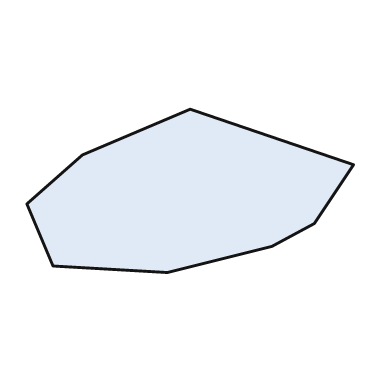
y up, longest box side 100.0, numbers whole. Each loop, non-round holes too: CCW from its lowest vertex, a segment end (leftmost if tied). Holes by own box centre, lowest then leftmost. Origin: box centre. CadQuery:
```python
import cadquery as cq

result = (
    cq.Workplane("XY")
    .moveTo(-7.0, -25.0)
    .lineTo(25.0, -17.0)
    .lineTo(38.0, -10.0)
    .lineTo(50.0, 8.0)
    .lineTo(0.0, 25.0)
    .lineTo(-33.0, 11.0)
    .lineTo(-50.0, -4.0)
    .lineTo(-42.0, -23.0)
    .close()
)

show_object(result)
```